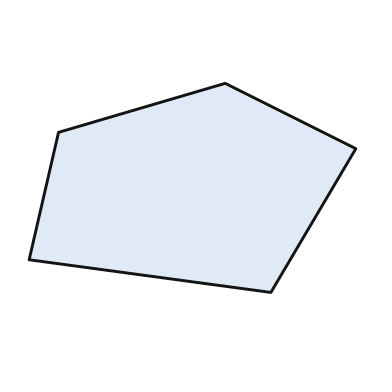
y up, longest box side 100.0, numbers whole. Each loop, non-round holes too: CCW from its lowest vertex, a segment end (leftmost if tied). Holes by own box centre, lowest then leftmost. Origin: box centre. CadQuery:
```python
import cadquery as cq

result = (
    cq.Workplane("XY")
    .moveTo(24.0, -32.0)
    .lineTo(50.0, 12.0)
    .lineTo(10.0, 32.0)
    .lineTo(-41.0, 17.0)
    .lineTo(-50.0, -22.0)
    .close()
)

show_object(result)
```